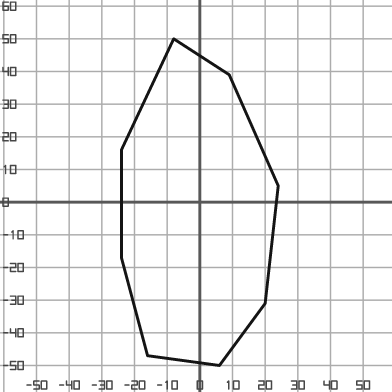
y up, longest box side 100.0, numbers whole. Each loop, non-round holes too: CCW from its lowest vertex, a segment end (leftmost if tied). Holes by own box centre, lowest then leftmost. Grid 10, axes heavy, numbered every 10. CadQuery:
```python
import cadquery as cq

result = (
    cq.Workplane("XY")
    .moveTo(6.0, -50.0)
    .lineTo(20.0, -31.0)
    .lineTo(24.0, 5.0)
    .lineTo(9.0, 39.0)
    .lineTo(-8.0, 50.0)
    .lineTo(-24.0, 16.0)
    .lineTo(-24.0, -17.0)
    .lineTo(-16.0, -47.0)
    .close()
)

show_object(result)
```